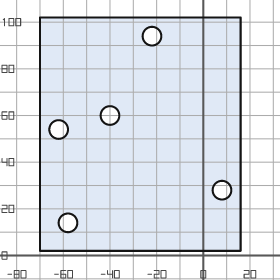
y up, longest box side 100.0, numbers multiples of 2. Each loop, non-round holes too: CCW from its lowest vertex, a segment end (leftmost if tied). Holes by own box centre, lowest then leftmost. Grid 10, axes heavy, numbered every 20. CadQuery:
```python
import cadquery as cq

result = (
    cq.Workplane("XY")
    .moveTo(-70.0, 2.0)
    .lineTo(16.0, 2.0)
    .lineTo(16.0, 102.0)
    .lineTo(-70.0, 102.0)
    .close()
    .moveTo(-58.0, 14.0)
    .circle(4.0)
    .moveTo(8.0, 28.0)
    .circle(4.0)
    .moveTo(-62.0, 54.0)
    .circle(4.0)
    .moveTo(-40.0, 60.0)
    .circle(4.0)
    .moveTo(-22.0, 94.0)
    .circle(4.0)
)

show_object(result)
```